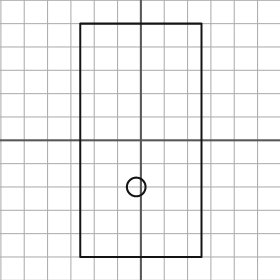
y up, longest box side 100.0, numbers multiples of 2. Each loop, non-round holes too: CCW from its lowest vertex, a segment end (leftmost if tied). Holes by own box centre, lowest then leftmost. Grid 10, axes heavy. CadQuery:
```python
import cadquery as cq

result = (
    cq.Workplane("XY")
    .moveTo(-26.0, -50.0)
    .lineTo(26.0, -50.0)
    .lineTo(26.0, 50.0)
    .lineTo(-26.0, 50.0)
    .close()
    .moveTo(-2.0, -20.0)
    .circle(4.0)
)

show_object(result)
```